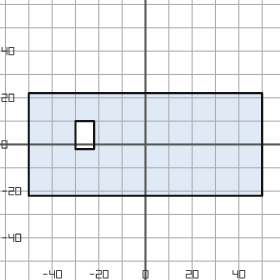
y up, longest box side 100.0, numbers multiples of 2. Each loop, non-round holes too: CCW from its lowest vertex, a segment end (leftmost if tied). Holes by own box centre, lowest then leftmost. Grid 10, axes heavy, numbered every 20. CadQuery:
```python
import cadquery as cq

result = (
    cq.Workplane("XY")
    .moveTo(-50.0, -22.0)
    .lineTo(50.0, -22.0)
    .lineTo(50.0, 22.0)
    .lineTo(-50.0, 22.0)
    .close()
    .moveTo(-30.0, -2.0)
    .lineTo(-22.0, -2.0)
    .lineTo(-22.0, 10.0)
    .lineTo(-30.0, 10.0)
    .close()
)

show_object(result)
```